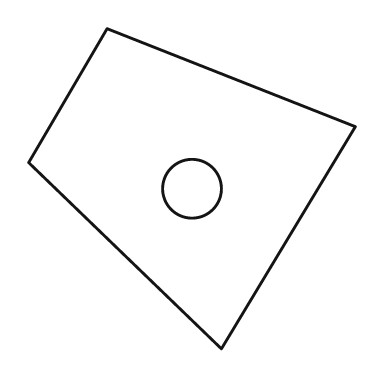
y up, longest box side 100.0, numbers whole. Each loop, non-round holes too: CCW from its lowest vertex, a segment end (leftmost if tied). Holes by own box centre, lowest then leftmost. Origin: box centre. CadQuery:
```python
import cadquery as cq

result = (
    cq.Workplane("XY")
    .moveTo(9.0, -49.0)
    .lineTo(50.0, 19.0)
    .lineTo(-26.0, 49.0)
    .lineTo(-50.0, 8.0)
    .close()
    .moveTo(0.0, 0.0)
    .circle(9.0)
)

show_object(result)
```